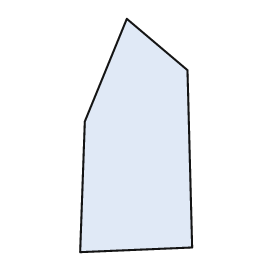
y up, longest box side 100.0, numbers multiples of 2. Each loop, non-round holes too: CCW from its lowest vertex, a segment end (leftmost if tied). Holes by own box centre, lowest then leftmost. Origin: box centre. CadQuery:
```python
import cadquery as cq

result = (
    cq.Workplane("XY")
    .moveTo(-24.0, -50.0)
    .lineTo(24.0, -48.0)
    .lineTo(22.0, 28.0)
    .lineTo(-4.0, 50.0)
    .lineTo(-22.0, 6.0)
    .close()
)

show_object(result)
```